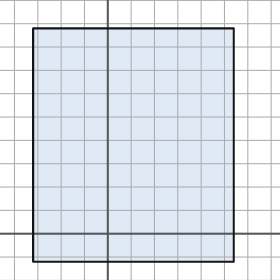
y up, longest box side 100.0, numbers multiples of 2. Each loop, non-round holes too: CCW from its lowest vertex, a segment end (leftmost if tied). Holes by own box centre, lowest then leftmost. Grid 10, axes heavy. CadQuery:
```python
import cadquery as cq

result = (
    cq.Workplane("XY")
    .moveTo(-32.0, -12.0)
    .lineTo(54.0, -12.0)
    .lineTo(54.0, 88.0)
    .lineTo(-32.0, 88.0)
    .close()
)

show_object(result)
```